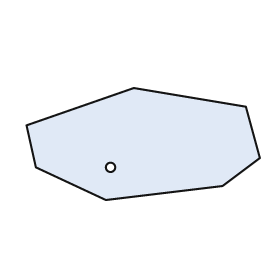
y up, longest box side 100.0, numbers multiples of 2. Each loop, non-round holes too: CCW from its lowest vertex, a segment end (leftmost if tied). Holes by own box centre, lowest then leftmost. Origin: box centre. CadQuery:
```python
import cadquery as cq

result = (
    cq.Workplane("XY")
    .moveTo(-16.0, -24.0)
    .lineTo(34.0, -18.0)
    .lineTo(50.0, -6.0)
    .lineTo(44.0, 16.0)
    .lineTo(-4.0, 24.0)
    .lineTo(-50.0, 8.0)
    .lineTo(-46.0, -10.0)
    .close()
    .moveTo(-14.0, -10.0)
    .circle(2.0)
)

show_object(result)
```